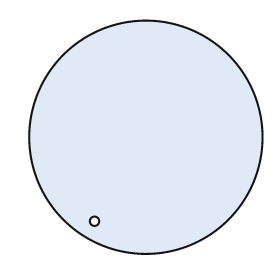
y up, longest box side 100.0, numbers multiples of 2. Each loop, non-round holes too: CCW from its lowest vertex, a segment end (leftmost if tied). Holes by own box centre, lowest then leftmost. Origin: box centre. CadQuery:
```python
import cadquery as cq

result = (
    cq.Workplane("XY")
    .moveTo(0.0, 0.0)
    .circle(50.0)
    .moveTo(-22.0, -36.0)
    .circle(2.0)
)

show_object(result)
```